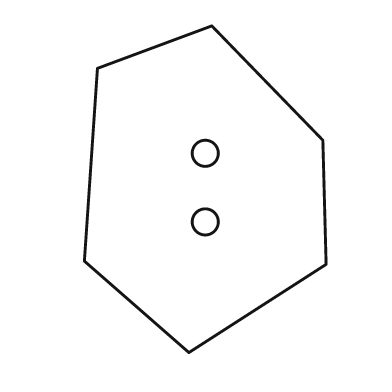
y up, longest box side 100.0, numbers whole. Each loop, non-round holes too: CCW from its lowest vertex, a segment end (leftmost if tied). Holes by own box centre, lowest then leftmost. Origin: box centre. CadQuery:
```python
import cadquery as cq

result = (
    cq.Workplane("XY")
    .moveTo(-5.0, -50.0)
    .lineTo(37.0, -23.0)
    .lineTo(36.0, 15.0)
    .lineTo(2.0, 50.0)
    .lineTo(-33.0, 37.0)
    .lineTo(-37.0, -22.0)
    .close()
    .moveTo(0.0, -10.0)
    .circle(4.0)
    .moveTo(0.0, 11.0)
    .circle(4.0)
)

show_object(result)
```